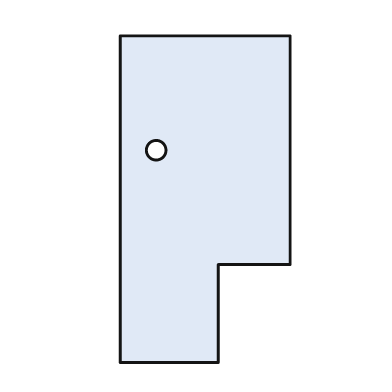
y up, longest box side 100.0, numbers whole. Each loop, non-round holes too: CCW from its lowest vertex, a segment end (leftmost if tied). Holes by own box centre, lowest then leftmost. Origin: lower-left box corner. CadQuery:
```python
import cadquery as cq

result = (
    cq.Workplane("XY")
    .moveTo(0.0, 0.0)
    .lineTo(30.0, 0.0)
    .lineTo(30.0, 30.0)
    .lineTo(52.0, 30.0)
    .lineTo(52.0, 100.0)
    .lineTo(0.0, 100.0)
    .close()
    .moveTo(11.0, 65.0)
    .circle(3.0)
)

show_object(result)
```